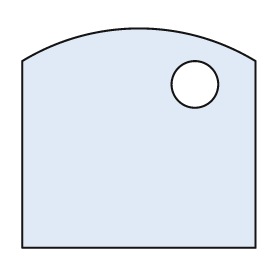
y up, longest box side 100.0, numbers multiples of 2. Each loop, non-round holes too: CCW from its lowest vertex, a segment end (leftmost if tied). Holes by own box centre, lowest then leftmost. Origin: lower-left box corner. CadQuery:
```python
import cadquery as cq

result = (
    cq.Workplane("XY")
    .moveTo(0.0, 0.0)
    .lineTo(100.0, 0.0)
    .lineTo(100.0, 80.0)
    .threePointArc((50.0, 94.0), (0.0, 80.0))
    .close()
    .moveTo(74.0, 70.0)
    .circle(10.0)
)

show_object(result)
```